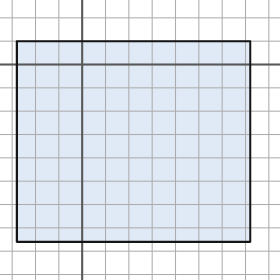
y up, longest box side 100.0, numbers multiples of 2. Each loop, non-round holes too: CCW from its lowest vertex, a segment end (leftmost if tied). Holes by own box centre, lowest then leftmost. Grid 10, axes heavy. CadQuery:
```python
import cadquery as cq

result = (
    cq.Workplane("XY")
    .moveTo(-28.0, -76.0)
    .lineTo(72.0, -76.0)
    .lineTo(72.0, 10.0)
    .lineTo(-28.0, 10.0)
    .close()
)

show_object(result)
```